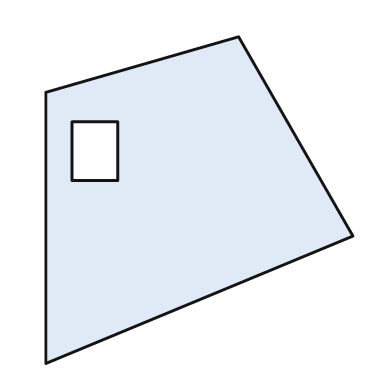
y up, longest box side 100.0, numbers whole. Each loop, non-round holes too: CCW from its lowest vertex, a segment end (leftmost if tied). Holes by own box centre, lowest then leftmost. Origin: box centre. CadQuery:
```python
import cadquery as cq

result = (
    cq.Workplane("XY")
    .moveTo(-47.0, -50.0)
    .lineTo(47.0, -11.0)
    .lineTo(12.0, 50.0)
    .lineTo(-47.0, 33.0)
    .close()
    .moveTo(-39.0, 6.0)
    .lineTo(-25.0, 6.0)
    .lineTo(-25.0, 24.0)
    .lineTo(-39.0, 24.0)
    .close()
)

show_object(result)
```